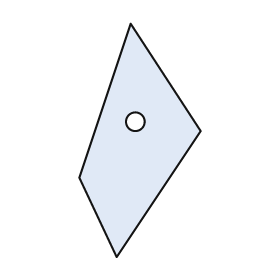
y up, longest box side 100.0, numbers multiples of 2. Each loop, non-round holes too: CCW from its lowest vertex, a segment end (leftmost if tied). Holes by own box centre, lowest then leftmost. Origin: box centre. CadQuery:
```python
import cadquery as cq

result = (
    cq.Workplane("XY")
    .moveTo(-10.0, -50.0)
    .lineTo(26.0, 4.0)
    .lineTo(-4.0, 50.0)
    .lineTo(-26.0, -16.0)
    .close()
    .moveTo(-2.0, 8.0)
    .circle(4.0)
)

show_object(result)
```